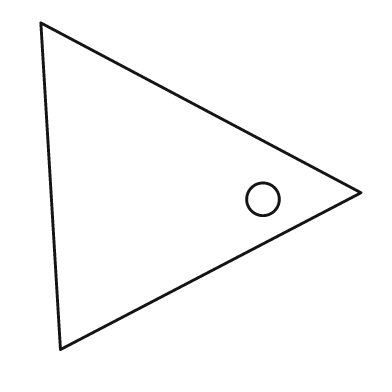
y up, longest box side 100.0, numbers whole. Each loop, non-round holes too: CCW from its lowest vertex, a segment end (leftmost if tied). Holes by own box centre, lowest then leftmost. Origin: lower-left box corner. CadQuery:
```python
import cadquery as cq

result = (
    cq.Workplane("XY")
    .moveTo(6.0, 0.0)
    .lineTo(98.0, 48.0)
    .lineTo(0.0, 100.0)
    .close()
    .moveTo(68.0, 46.0)
    .circle(5.0)
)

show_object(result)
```